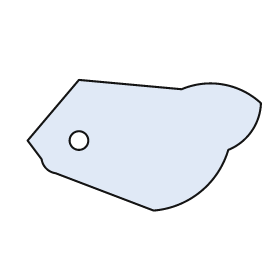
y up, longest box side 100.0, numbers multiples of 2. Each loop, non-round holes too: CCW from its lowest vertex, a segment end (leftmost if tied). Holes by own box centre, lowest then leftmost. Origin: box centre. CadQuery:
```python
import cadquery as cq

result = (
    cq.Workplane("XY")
    .moveTo(4.0, -28.0)
    .threePointArc((24.0, -20.0), (36.0, -2.0))
    .threePointArc((46.0, 6.0), (50.0, 18.0))
    .threePointArc((34.0, 26.0), (16.0, 24.0))
    .lineTo(-28.0, 28.0)
    .lineTo(-50.0, 2.0)
    .lineTo(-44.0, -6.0)
    .threePointArc((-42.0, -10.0), (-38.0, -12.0))
    .close()
    .moveTo(-28.0, 2.0)
    .circle(4.0)
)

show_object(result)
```